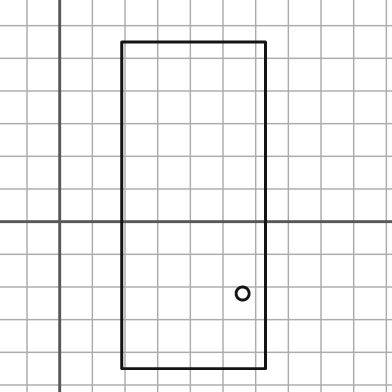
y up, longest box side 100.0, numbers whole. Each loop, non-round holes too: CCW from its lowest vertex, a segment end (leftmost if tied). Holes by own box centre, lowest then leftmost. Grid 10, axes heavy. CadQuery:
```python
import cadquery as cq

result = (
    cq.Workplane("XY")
    .moveTo(19.0, -45.0)
    .lineTo(63.0, -45.0)
    .lineTo(63.0, 55.0)
    .lineTo(19.0, 55.0)
    .close()
    .moveTo(56.0, -22.0)
    .circle(2.0)
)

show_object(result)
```